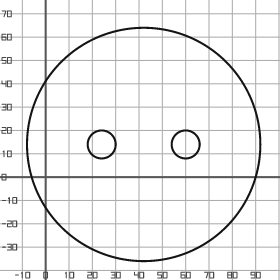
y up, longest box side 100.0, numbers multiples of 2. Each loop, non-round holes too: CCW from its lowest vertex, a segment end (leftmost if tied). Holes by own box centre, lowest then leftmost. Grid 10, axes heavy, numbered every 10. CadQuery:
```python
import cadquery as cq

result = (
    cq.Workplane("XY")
    .moveTo(42.0, 14.0)
    .circle(50.0)
    .moveTo(24.0, 14.0)
    .circle(6.0)
    .moveTo(60.0, 14.0)
    .circle(6.0)
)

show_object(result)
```